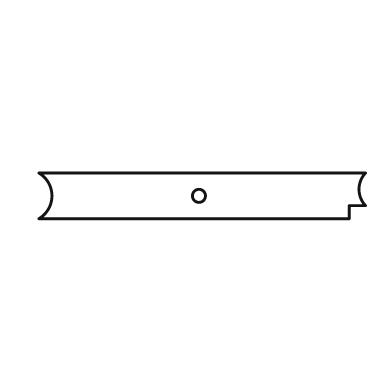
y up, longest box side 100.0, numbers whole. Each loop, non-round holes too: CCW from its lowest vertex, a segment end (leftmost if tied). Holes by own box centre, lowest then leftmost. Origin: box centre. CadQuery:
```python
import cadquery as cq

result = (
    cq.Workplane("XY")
    .moveTo(-50.0, -7.0)
    .lineTo(45.0, -7.0)
    .lineTo(45.0, -3.0)
    .lineTo(50.0, -3.0)
    .threePointArc((48.0, 2.0), (50.0, 7.0))
    .lineTo(-50.0, 7.0)
    .threePointArc((-46.0, 0.0), (-50.0, -7.0))
    .close()
    .moveTo(-1.0, 0.0)
    .circle(2.0)
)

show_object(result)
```